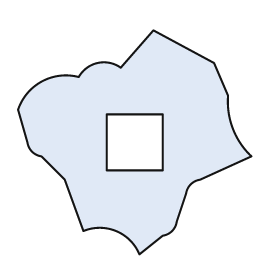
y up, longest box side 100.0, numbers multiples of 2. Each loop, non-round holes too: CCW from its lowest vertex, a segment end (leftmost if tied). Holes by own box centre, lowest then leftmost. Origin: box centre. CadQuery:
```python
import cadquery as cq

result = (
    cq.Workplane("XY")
    .moveTo(2.0, -48.0)
    .lineTo(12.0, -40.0)
    .threePointArc((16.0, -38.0), (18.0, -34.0))
    .lineTo(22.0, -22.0)
    .threePointArc((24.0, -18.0), (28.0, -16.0))
    .lineTo(50.0, -6.0)
    .threePointArc((42.0, 6.0), (40.0, 20.0))
    .lineTo(34.0, 34.0)
    .lineTo(8.0, 48.0)
    .lineTo(-6.0, 32.0)
    .threePointArc((-16.0, 34.0), (-24.0, 28.0))
    .threePointArc((-40.0, 26.0), (-50.0, 14.0))
    .lineTo(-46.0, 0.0)
    .threePointArc((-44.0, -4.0), (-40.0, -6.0))
    .lineTo(-30.0, -16.0)
    .lineTo(-22.0, -38.0)
    .threePointArc((-8.0, -38.0), (2.0, -48.0))
    .close()
    .moveTo(-12.0, -12.0)
    .lineTo(12.0, -12.0)
    .lineTo(12.0, 12.0)
    .lineTo(-12.0, 12.0)
    .close()
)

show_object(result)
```